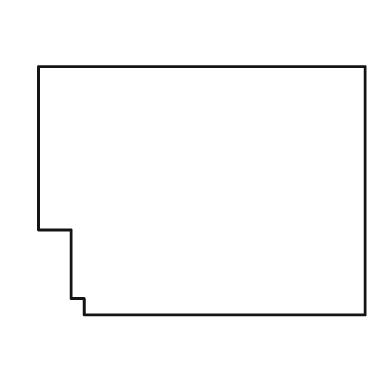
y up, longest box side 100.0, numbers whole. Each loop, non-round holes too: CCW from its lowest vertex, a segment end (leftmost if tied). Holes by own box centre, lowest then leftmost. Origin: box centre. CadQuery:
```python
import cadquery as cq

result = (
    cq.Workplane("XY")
    .moveTo(-36.0, -38.0)
    .lineTo(50.0, -38.0)
    .lineTo(50.0, 38.0)
    .lineTo(-50.0, 38.0)
    .lineTo(-50.0, -12.0)
    .lineTo(-40.0, -12.0)
    .lineTo(-40.0, -33.0)
    .lineTo(-36.0, -33.0)
    .close()
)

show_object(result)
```